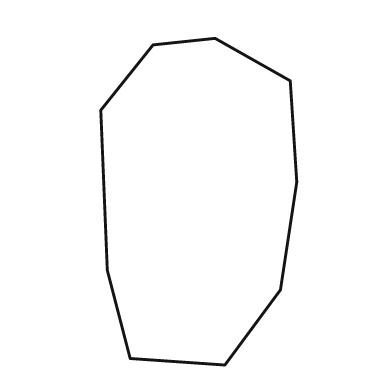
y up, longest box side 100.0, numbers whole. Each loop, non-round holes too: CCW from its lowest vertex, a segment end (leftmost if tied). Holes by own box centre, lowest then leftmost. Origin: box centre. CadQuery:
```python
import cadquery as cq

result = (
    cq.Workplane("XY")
    .moveTo(8.0, -50.0)
    .lineTo(25.0, -27.0)
    .lineTo(30.0, 6.0)
    .lineTo(28.0, 37.0)
    .lineTo(5.0, 50.0)
    .lineTo(-14.0, 48.0)
    .lineTo(-30.0, 28.0)
    .lineTo(-28.0, -21.0)
    .lineTo(-21.0, -48.0)
    .close()
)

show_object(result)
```